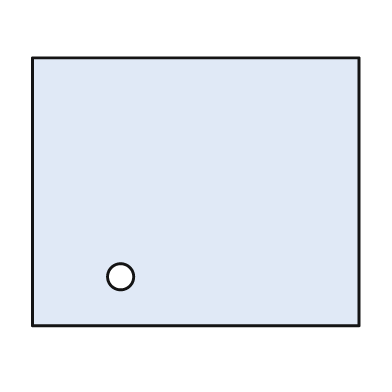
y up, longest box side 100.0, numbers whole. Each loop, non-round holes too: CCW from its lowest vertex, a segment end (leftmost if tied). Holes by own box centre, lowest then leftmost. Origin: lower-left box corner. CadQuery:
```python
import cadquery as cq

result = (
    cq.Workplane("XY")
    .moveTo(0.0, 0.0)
    .lineTo(100.0, 0.0)
    .lineTo(100.0, 82.0)
    .lineTo(0.0, 82.0)
    .close()
    .moveTo(27.0, 15.0)
    .circle(4.0)
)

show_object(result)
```